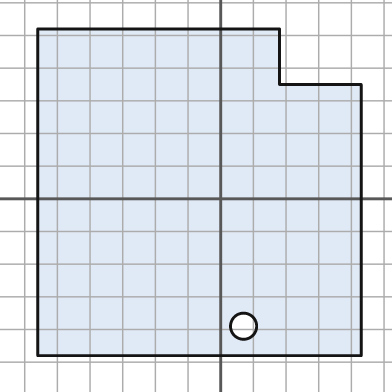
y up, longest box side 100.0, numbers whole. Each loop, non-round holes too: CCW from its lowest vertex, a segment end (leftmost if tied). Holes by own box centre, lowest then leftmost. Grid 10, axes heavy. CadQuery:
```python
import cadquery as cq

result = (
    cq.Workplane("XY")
    .moveTo(-56.0, -48.0)
    .lineTo(43.0, -48.0)
    .lineTo(43.0, 35.0)
    .lineTo(18.0, 35.0)
    .lineTo(18.0, 52.0)
    .lineTo(-56.0, 52.0)
    .close()
    .moveTo(7.0, -39.0)
    .circle(4.0)
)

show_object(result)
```